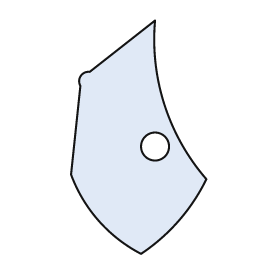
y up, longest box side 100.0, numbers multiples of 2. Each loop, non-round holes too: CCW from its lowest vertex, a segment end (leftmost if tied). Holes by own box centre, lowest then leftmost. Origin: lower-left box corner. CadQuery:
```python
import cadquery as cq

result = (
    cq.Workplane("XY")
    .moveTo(30.0, 0.0)
    .threePointArc((46.0, 14.0), (58.0, 32.0))
    .threePointArc((40.0, 64.0), (36.0, 100.0))
    .lineTo(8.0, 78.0)
    .threePointArc((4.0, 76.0), (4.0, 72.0))
    .lineTo(0.0, 34.0)
    .threePointArc((12.0, 14.0), (30.0, 0.0))
    .close()
    .moveTo(36.0, 46.0)
    .circle(6.0)
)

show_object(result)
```